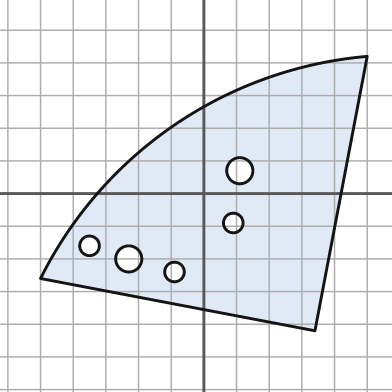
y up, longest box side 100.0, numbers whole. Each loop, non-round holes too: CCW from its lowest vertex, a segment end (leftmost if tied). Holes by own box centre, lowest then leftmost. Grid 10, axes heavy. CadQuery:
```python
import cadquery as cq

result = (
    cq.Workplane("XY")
    .moveTo(34.0, -42.0)
    .lineTo(50.0, 42.0)
    .threePointArc((-9.0, 21.0), (-50.0, -26.0))
    .close()
    .moveTo(-9.0, -24.0)
    .circle(3.0)
    .moveTo(-23.0, -20.0)
    .circle(4.0)
    .moveTo(-35.0, -16.0)
    .circle(3.0)
    .moveTo(9.0, -9.0)
    .circle(3.0)
    .moveTo(11.0, 7.0)
    .circle(4.0)
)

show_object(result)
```